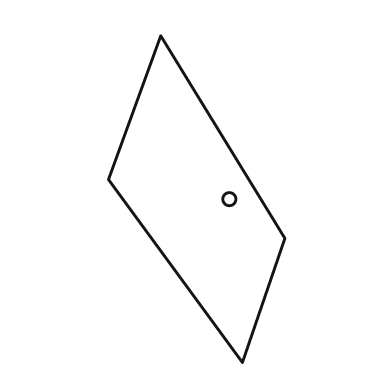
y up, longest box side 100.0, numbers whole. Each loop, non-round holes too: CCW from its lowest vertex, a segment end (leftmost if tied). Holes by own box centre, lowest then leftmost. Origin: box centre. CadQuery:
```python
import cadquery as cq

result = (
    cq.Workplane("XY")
    .moveTo(14.0, -50.0)
    .lineTo(27.0, -12.0)
    .lineTo(-11.0, 50.0)
    .lineTo(-27.0, 6.0)
    .close()
    .moveTo(10.0, 0.0)
    .circle(2.0)
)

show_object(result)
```